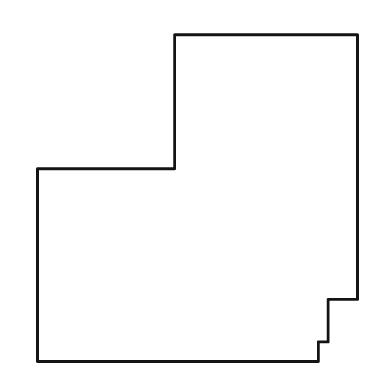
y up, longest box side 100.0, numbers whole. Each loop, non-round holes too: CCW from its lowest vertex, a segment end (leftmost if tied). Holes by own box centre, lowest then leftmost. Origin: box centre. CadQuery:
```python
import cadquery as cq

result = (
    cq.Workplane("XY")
    .moveTo(-49.0, -50.0)
    .lineTo(37.0, -50.0)
    .lineTo(37.0, -44.0)
    .lineTo(40.0, -44.0)
    .lineTo(40.0, -31.0)
    .lineTo(49.0, -31.0)
    .lineTo(49.0, 50.0)
    .lineTo(-7.0, 50.0)
    .lineTo(-7.0, 9.0)
    .lineTo(-49.0, 9.0)
    .close()
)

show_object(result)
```